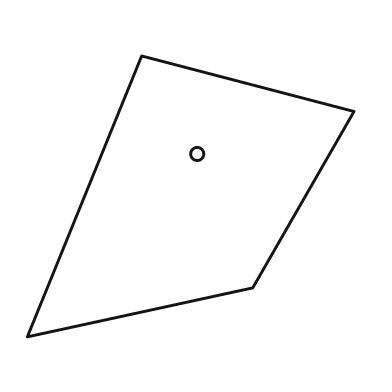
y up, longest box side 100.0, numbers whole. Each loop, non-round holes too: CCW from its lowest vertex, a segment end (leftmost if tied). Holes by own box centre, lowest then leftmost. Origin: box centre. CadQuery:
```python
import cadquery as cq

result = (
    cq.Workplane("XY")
    .moveTo(-50.0, -43.0)
    .lineTo(19.0, -28.0)
    .lineTo(50.0, 26.0)
    .lineTo(-15.0, 43.0)
    .close()
    .moveTo(2.0, 13.0)
    .circle(2.0)
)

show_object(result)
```